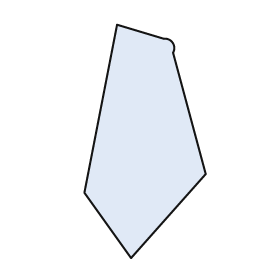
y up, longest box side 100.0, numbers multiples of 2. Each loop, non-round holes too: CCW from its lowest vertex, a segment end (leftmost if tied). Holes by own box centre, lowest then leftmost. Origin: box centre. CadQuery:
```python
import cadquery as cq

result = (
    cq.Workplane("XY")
    .moveTo(-6.0, -50.0)
    .lineTo(26.0, -14.0)
    .lineTo(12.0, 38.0)
    .threePointArc((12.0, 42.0), (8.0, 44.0))
    .lineTo(-12.0, 50.0)
    .lineTo(-26.0, -22.0)
    .close()
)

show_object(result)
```